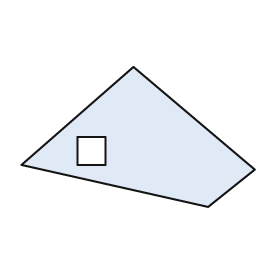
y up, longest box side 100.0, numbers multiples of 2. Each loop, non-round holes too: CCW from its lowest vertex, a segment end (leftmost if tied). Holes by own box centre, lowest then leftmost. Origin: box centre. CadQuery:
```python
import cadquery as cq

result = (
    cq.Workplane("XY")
    .moveTo(30.0, -30.0)
    .lineTo(50.0, -14.0)
    .lineTo(-2.0, 30.0)
    .lineTo(-50.0, -12.0)
    .close()
    .moveTo(-26.0, -12.0)
    .lineTo(-14.0, -12.0)
    .lineTo(-14.0, 0.0)
    .lineTo(-26.0, 0.0)
    .close()
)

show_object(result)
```